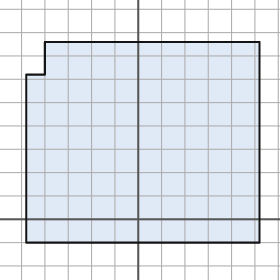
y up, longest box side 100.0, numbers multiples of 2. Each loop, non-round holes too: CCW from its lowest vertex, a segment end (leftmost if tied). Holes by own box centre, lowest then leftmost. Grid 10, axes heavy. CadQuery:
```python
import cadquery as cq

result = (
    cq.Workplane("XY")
    .moveTo(-48.0, -10.0)
    .lineTo(52.0, -10.0)
    .lineTo(52.0, 76.0)
    .lineTo(-40.0, 76.0)
    .lineTo(-40.0, 62.0)
    .lineTo(-48.0, 62.0)
    .close()
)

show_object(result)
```